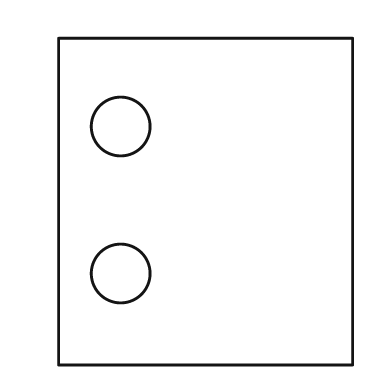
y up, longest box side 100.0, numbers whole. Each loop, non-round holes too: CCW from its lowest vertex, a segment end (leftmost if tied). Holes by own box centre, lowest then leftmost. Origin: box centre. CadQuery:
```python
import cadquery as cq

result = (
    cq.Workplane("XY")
    .moveTo(-45.0, -50.0)
    .lineTo(45.0, -50.0)
    .lineTo(45.0, 50.0)
    .lineTo(-45.0, 50.0)
    .close()
    .moveTo(-26.0, -22.0)
    .circle(9.0)
    .moveTo(-26.0, 23.0)
    .circle(9.0)
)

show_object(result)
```